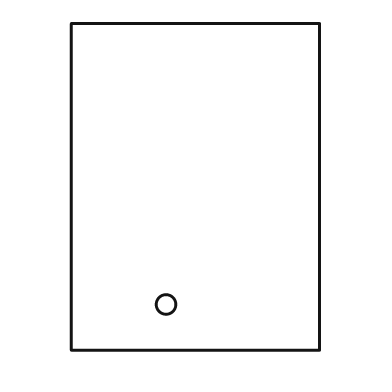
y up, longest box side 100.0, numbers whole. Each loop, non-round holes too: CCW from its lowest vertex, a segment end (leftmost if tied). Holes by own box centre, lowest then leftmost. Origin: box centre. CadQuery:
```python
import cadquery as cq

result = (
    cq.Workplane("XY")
    .moveTo(-38.0, -50.0)
    .lineTo(38.0, -50.0)
    .lineTo(38.0, 50.0)
    .lineTo(-38.0, 50.0)
    .close()
    .moveTo(-9.0, -36.0)
    .circle(3.0)
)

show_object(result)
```